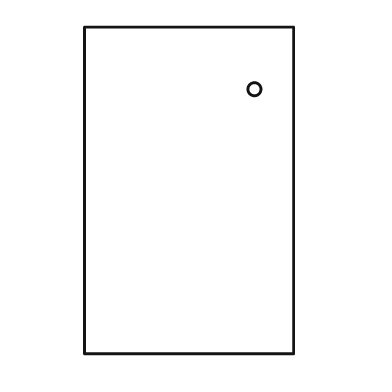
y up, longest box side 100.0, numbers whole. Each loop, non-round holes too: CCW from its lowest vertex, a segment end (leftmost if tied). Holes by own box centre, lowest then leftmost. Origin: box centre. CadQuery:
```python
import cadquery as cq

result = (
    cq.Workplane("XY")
    .moveTo(-32.0, -50.0)
    .lineTo(32.0, -50.0)
    .lineTo(32.0, 50.0)
    .lineTo(-32.0, 50.0)
    .close()
    .moveTo(20.0, 31.0)
    .circle(2.0)
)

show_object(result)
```